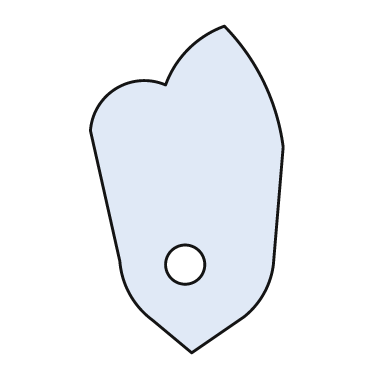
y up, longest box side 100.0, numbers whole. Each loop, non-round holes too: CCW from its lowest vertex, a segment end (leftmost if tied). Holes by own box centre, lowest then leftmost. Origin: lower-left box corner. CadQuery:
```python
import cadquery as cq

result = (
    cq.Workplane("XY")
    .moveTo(31.0, 0.0)
    .lineTo(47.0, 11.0)
    .threePointArc((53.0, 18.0), (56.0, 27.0))
    .lineTo(59.0, 63.0)
    .threePointArc((53.0, 83.0), (41.0, 100.0))
    .threePointArc((30.0, 93.0), (23.0, 82.0))
    .threePointArc((8.0, 81.0), (0.0, 68.0))
    .lineTo(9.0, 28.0)
    .threePointArc((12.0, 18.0), (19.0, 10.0))
    .close()
    .moveTo(29.0, 27.0)
    .circle(6.0)
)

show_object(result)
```